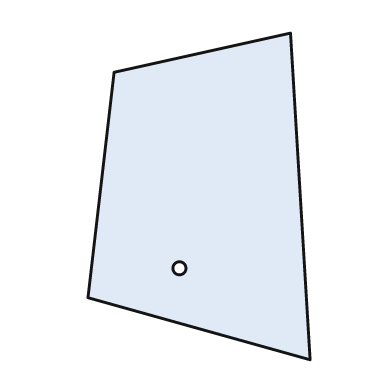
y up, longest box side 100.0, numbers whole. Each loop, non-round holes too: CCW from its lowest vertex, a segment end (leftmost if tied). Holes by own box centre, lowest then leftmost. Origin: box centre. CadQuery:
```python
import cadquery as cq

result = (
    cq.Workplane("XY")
    .moveTo(34.0, -50.0)
    .lineTo(28.0, 50.0)
    .lineTo(-26.0, 38.0)
    .lineTo(-34.0, -31.0)
    .close()
    .moveTo(-6.0, -22.0)
    .circle(2.0)
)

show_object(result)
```